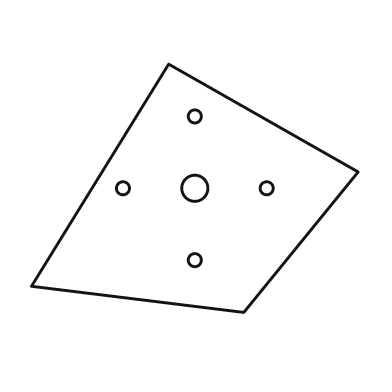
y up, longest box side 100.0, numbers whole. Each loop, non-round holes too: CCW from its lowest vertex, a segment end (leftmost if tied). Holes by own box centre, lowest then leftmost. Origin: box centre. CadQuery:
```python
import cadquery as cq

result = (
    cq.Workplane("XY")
    .moveTo(15.0, -38.0)
    .lineTo(50.0, 5.0)
    .lineTo(-8.0, 38.0)
    .lineTo(-50.0, -30.0)
    .close()
    .moveTo(0.0, -22.0)
    .circle(2.0)
    .moveTo(-22.0, 0.0)
    .circle(2.0)
    .moveTo(0.0, 0.0)
    .circle(4.0)
    .moveTo(22.0, 0.0)
    .circle(2.0)
    .moveTo(0.0, 22.0)
    .circle(2.0)
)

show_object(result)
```